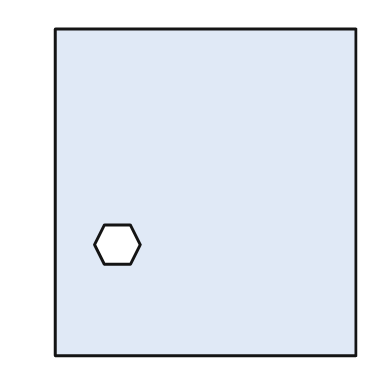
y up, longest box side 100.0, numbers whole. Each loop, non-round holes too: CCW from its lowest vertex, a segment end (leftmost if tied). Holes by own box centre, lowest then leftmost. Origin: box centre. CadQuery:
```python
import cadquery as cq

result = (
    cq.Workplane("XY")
    .moveTo(-46.0, -50.0)
    .lineTo(46.0, -50.0)
    .lineTo(46.0, 50.0)
    .lineTo(-46.0, 50.0)
    .close()
    .moveTo(-31.0, -22.0)
    .lineTo(-23.0, -22.0)
    .lineTo(-20.0, -16.0)
    .lineTo(-23.0, -10.0)
    .lineTo(-31.0, -10.0)
    .lineTo(-34.0, -16.0)
    .close()
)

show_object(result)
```